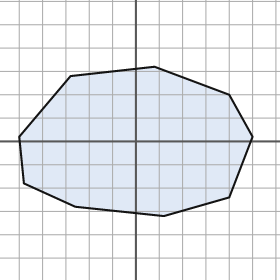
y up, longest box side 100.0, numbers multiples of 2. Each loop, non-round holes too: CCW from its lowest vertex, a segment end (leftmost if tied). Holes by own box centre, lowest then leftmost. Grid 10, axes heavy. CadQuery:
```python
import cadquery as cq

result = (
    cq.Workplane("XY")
    .moveTo(12.0, -32.0)
    .lineTo(40.0, -24.0)
    .lineTo(50.0, 2.0)
    .lineTo(40.0, 20.0)
    .lineTo(8.0, 32.0)
    .lineTo(-28.0, 28.0)
    .lineTo(-50.0, 2.0)
    .lineTo(-48.0, -18.0)
    .lineTo(-26.0, -28.0)
    .close()
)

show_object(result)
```